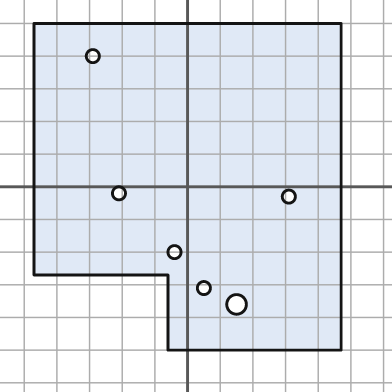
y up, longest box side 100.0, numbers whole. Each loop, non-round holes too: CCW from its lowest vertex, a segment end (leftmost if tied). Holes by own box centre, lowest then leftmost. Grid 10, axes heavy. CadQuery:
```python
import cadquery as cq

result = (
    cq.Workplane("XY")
    .moveTo(-6.0, -50.0)
    .lineTo(47.0, -50.0)
    .lineTo(47.0, 50.0)
    .lineTo(-47.0, 50.0)
    .lineTo(-47.0, -27.0)
    .lineTo(-6.0, -27.0)
    .close()
    .moveTo(15.0, -36.0)
    .circle(3.0)
    .moveTo(5.0, -31.0)
    .circle(2.0)
    .moveTo(-4.0, -20.0)
    .circle(2.0)
    .moveTo(31.0, -3.0)
    .circle(2.0)
    .moveTo(-21.0, -2.0)
    .circle(2.0)
    .moveTo(-29.0, 40.0)
    .circle(2.0)
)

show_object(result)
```